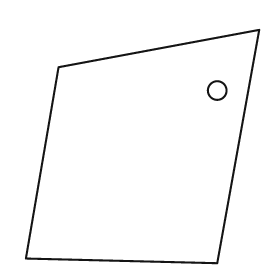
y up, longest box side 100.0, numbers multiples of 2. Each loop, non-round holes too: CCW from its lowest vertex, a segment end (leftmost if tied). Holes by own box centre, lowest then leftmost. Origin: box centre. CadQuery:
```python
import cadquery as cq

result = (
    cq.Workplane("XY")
    .moveTo(32.0, -50.0)
    .lineTo(50.0, 50.0)
    .lineTo(-36.0, 34.0)
    .lineTo(-50.0, -48.0)
    .close()
    .moveTo(32.0, 24.0)
    .circle(4.0)
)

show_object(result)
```